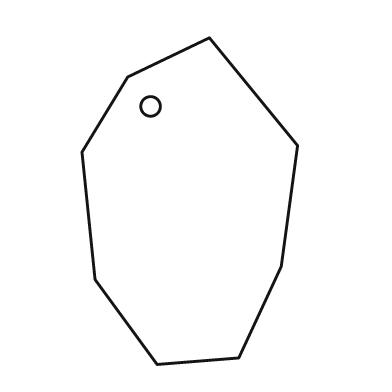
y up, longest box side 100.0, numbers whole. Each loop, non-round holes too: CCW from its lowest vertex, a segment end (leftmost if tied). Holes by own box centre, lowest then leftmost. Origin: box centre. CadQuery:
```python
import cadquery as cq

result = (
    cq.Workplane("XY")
    .moveTo(-10.0, -50.0)
    .lineTo(15.0, -48.0)
    .lineTo(28.0, -20.0)
    .lineTo(33.0, 17.0)
    .lineTo(6.0, 50.0)
    .lineTo(-19.0, 38.0)
    .lineTo(-33.0, 15.0)
    .lineTo(-29.0, -24.0)
    .close()
    .moveTo(-12.0, 29.0)
    .circle(3.0)
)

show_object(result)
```